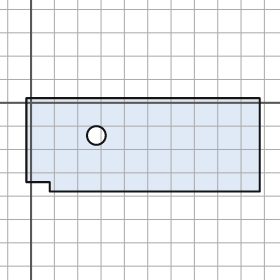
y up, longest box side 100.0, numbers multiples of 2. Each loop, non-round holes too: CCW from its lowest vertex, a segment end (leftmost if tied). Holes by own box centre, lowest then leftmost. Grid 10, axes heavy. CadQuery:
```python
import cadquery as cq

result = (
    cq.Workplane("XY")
    .moveTo(8.0, -38.0)
    .lineTo(98.0, -38.0)
    .lineTo(98.0, 2.0)
    .lineTo(-2.0, 2.0)
    .lineTo(-2.0, -34.0)
    .lineTo(8.0, -34.0)
    .close()
    .moveTo(28.0, -14.0)
    .circle(4.0)
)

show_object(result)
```